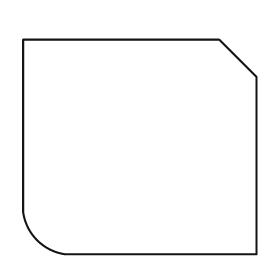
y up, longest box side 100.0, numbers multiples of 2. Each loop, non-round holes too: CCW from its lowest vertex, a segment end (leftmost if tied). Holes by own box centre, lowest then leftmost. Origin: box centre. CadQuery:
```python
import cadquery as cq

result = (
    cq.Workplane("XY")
    .moveTo(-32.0, -46.0)
    .lineTo(50.0, -46.0)
    .lineTo(50.0, 30.0)
    .lineTo(34.0, 46.0)
    .lineTo(-50.0, 46.0)
    .lineTo(-50.0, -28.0)
    .threePointArc((-44.0, -40.0), (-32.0, -46.0))
    .close()
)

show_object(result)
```